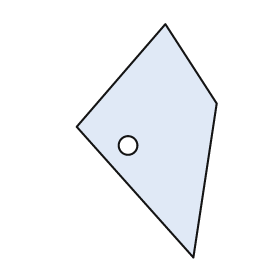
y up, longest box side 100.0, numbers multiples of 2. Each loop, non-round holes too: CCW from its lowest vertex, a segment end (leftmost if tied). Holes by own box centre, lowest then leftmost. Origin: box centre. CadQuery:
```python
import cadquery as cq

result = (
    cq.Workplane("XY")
    .moveTo(20.0, -50.0)
    .lineTo(30.0, 16.0)
    .lineTo(8.0, 50.0)
    .lineTo(-30.0, 6.0)
    .close()
    .moveTo(-8.0, -2.0)
    .circle(4.0)
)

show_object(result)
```